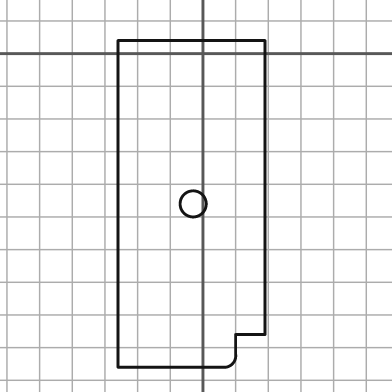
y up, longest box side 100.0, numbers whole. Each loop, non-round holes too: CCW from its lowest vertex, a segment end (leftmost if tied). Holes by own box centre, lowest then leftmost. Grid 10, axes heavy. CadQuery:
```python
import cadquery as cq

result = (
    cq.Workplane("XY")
    .moveTo(-26.0, -96.0)
    .lineTo(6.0, -96.0)
    .threePointArc((9.0, -95.0), (10.0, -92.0))
    .lineTo(10.0, -86.0)
    .lineTo(19.0, -86.0)
    .lineTo(19.0, 4.0)
    .lineTo(-26.0, 4.0)
    .close()
    .moveTo(-3.0, -46.0)
    .circle(4.0)
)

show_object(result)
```